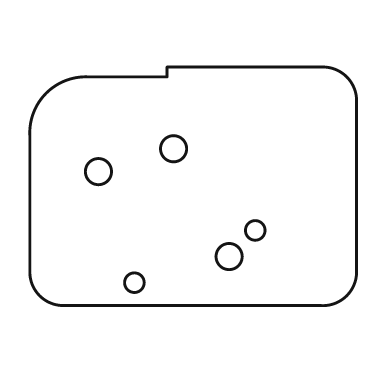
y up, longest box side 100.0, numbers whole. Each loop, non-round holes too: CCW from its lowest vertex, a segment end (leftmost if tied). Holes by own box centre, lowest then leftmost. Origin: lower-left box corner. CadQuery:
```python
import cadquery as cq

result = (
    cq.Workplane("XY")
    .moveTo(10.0, 0.0)
    .lineTo(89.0, 0.0)
    .threePointArc((97.0, 3.0), (100.0, 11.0))
    .lineTo(100.0, 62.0)
    .threePointArc((97.0, 70.0), (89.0, 73.0))
    .lineTo(42.0, 73.0)
    .lineTo(42.0, 70.0)
    .lineTo(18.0, 70.0)
    .threePointArc((5.0, 65.0), (0.0, 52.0))
    .lineTo(0.0, 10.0)
    .threePointArc((3.0, 3.0), (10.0, 0.0))
    .close()
    .moveTo(32.0, 7.0)
    .circle(3.0)
    .moveTo(61.0, 15.0)
    .circle(4.0)
    .moveTo(69.0, 23.0)
    .circle(3.0)
    .moveTo(21.0, 41.0)
    .circle(4.0)
    .moveTo(44.0, 48.0)
    .circle(4.0)
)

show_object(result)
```